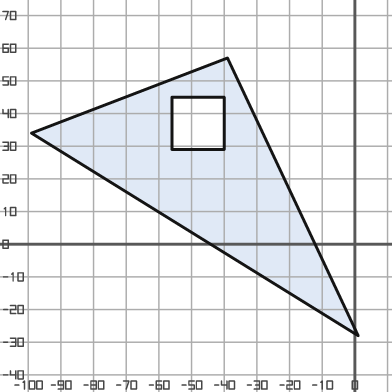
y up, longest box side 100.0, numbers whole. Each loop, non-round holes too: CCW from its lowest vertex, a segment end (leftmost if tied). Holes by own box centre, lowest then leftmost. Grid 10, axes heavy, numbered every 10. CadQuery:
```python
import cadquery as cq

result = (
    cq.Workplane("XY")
    .moveTo(1.0, -28.0)
    .lineTo(-39.0, 57.0)
    .lineTo(-99.0, 34.0)
    .close()
    .moveTo(-56.0, 29.0)
    .lineTo(-40.0, 29.0)
    .lineTo(-40.0, 45.0)
    .lineTo(-56.0, 45.0)
    .close()
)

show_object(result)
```